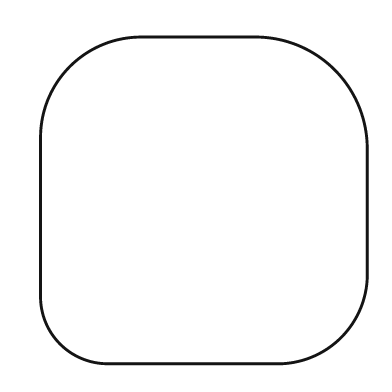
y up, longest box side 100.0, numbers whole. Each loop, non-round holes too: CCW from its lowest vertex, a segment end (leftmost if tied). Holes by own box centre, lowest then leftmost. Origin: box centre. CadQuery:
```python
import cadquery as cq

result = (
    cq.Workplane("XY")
    .moveTo(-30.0, -50.0)
    .lineTo(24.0, -50.0)
    .threePointArc((42.0, -42.0), (50.0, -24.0))
    .lineTo(50.0, 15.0)
    .threePointArc((40.0, 40.0), (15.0, 50.0))
    .lineTo(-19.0, 50.0)
    .threePointArc((-41.0, 41.0), (-50.0, 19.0))
    .lineTo(-50.0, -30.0)
    .threePointArc((-44.0, -44.0), (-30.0, -50.0))
    .close()
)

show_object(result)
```